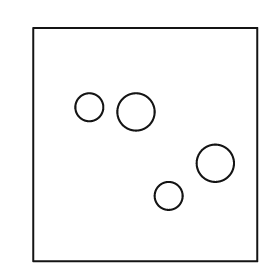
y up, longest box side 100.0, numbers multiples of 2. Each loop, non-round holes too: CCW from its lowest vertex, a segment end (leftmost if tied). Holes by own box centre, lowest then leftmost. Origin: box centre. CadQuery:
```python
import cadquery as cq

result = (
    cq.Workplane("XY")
    .moveTo(-48.0, -50.0)
    .lineTo(48.0, -50.0)
    .lineTo(48.0, 50.0)
    .lineTo(-48.0, 50.0)
    .close()
    .moveTo(10.0, -22.0)
    .circle(6.0)
    .moveTo(30.0, -8.0)
    .circle(8.0)
    .moveTo(-4.0, 14.0)
    .circle(8.0)
    .moveTo(-24.0, 16.0)
    .circle(6.0)
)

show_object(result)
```